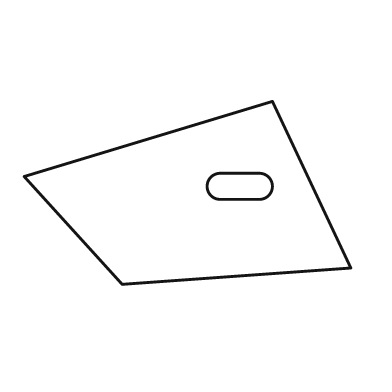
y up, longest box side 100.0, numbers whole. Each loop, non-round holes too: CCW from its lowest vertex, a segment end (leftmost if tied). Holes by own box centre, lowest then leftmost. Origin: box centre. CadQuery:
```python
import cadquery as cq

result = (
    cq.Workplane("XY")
    .moveTo(-20.0, -28.0)
    .lineTo(50.0, -23.0)
    .lineTo(26.0, 28.0)
    .lineTo(-50.0, 5.0)
    .close()
    .moveTo(10.0, -2.0)
    .lineTo(22.0, -2.0)
    .threePointArc((26.0, 2.0), (22.0, 6.0))
    .lineTo(10.0, 6.0)
    .threePointArc((6.0, 2.0), (10.0, -2.0))
    .close()
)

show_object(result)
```